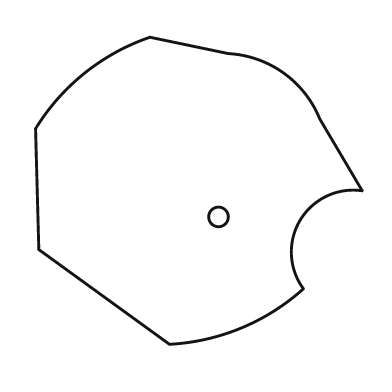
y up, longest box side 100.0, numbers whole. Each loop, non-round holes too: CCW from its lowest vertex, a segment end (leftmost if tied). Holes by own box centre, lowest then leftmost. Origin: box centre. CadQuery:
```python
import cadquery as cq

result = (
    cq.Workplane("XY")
    .moveTo(-9.0, -47.0)
    .threePointArc((13.0, -42.0), (32.0, -30.0))
    .threePointArc((31.0, -9.0), (50.0, 0.0))
    .lineTo(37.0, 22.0)
    .threePointArc((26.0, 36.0), (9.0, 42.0))
    .lineTo(-15.0, 47.0)
    .threePointArc((-35.0, 36.0), (-50.0, 19.0))
    .lineTo(-49.0, -18.0)
    .close()
    .moveTo(6.0, -8.0)
    .circle(3.0)
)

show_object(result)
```